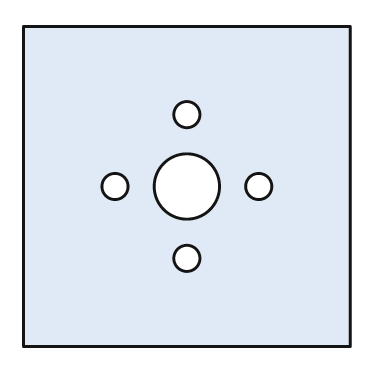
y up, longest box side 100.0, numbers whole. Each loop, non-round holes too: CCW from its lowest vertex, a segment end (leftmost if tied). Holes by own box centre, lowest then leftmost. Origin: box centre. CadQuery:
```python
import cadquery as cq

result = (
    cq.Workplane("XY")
    .moveTo(-50.0, -49.0)
    .lineTo(50.0, -49.0)
    .lineTo(50.0, 49.0)
    .lineTo(-50.0, 49.0)
    .close()
    .moveTo(0.0, -22.0)
    .circle(4.0)
    .moveTo(-22.0, 0.0)
    .circle(4.0)
    .moveTo(0.0, 0.0)
    .circle(10.0)
    .moveTo(22.0, 0.0)
    .circle(4.0)
    .moveTo(0.0, 22.0)
    .circle(4.0)
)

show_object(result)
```